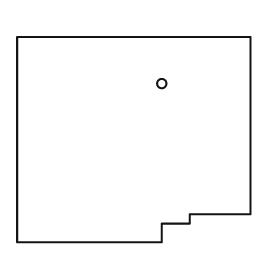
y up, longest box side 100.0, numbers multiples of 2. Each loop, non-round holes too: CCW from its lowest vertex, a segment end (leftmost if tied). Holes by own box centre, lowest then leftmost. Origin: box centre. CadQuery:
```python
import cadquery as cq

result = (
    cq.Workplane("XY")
    .moveTo(-50.0, -44.0)
    .lineTo(12.0, -44.0)
    .lineTo(12.0, -36.0)
    .lineTo(24.0, -36.0)
    .lineTo(24.0, -32.0)
    .lineTo(50.0, -32.0)
    .lineTo(50.0, 44.0)
    .lineTo(-50.0, 44.0)
    .close()
    .moveTo(12.0, 24.0)
    .circle(2.0)
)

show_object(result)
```